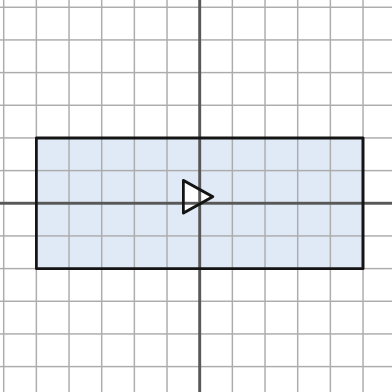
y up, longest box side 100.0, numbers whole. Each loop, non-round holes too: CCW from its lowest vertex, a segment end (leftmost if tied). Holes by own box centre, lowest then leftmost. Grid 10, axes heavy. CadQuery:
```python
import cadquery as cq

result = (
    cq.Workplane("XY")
    .moveTo(-50.0, -20.0)
    .lineTo(50.0, -20.0)
    .lineTo(50.0, 20.0)
    .lineTo(-50.0, 20.0)
    .close()
    .moveTo(-5.0, -3.0)
    .lineTo(4.0, 2.0)
    .lineTo(-5.0, 7.0)
    .close()
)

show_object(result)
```